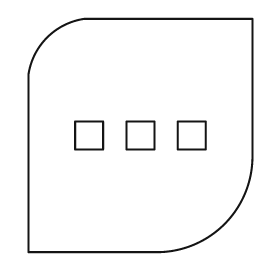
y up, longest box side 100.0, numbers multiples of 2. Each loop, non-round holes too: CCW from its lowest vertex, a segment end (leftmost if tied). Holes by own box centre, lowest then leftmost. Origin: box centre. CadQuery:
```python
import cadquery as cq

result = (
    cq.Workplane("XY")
    .moveTo(-48.0, -50.0)
    .lineTo(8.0, -50.0)
    .threePointArc((36.0, -38.0), (48.0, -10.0))
    .lineTo(48.0, 50.0)
    .lineTo(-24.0, 50.0)
    .threePointArc((-40.0, 42.0), (-48.0, 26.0))
    .close()
    .moveTo(-28.0, -6.0)
    .lineTo(-16.0, -6.0)
    .lineTo(-16.0, 6.0)
    .lineTo(-28.0, 6.0)
    .close()
    .moveTo(-6.0, -6.0)
    .lineTo(6.0, -6.0)
    .lineTo(6.0, 6.0)
    .lineTo(-6.0, 6.0)
    .close()
    .moveTo(16.0, -6.0)
    .lineTo(28.0, -6.0)
    .lineTo(28.0, 6.0)
    .lineTo(16.0, 6.0)
    .close()
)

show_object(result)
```